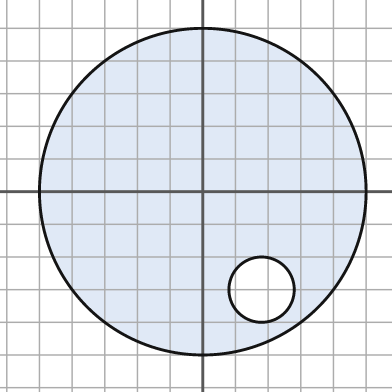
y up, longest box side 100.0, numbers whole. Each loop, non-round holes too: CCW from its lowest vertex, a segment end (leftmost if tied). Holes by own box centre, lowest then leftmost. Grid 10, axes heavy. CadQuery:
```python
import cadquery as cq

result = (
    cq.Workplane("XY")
    .moveTo(0.0, 0.0)
    .circle(50.0)
    .moveTo(18.0, -30.0)
    .circle(10.0)
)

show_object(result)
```